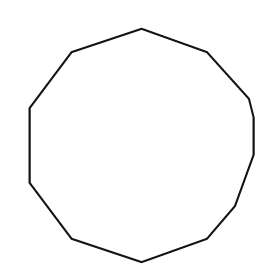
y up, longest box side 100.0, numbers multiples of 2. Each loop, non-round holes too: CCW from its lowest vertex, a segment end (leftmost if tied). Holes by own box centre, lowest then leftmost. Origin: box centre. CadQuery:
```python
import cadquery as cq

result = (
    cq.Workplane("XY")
    .moveTo(0.0, -50.0)
    .lineTo(28.0, -40.0)
    .lineTo(40.0, -26.0)
    .lineTo(48.0, -4.0)
    .lineTo(48.0, 12.0)
    .lineTo(46.0, 20.0)
    .lineTo(28.0, 40.0)
    .lineTo(0.0, 50.0)
    .lineTo(-30.0, 40.0)
    .lineTo(-48.0, 16.0)
    .lineTo(-48.0, -16.0)
    .lineTo(-30.0, -40.0)
    .close()
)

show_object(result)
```